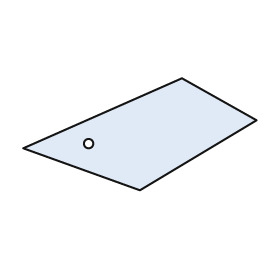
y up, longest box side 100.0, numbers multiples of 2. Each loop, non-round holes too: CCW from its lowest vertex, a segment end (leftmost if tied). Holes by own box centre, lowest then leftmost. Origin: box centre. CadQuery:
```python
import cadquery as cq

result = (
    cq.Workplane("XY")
    .moveTo(0.0, -24.0)
    .lineTo(50.0, 6.0)
    .lineTo(18.0, 24.0)
    .lineTo(-50.0, -6.0)
    .close()
    .moveTo(-22.0, -4.0)
    .circle(2.0)
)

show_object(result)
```